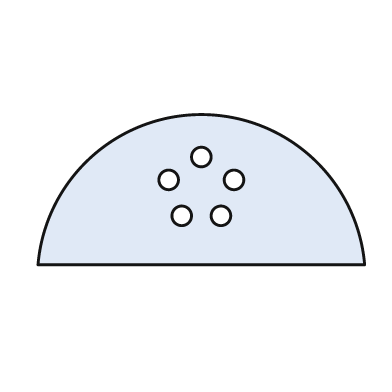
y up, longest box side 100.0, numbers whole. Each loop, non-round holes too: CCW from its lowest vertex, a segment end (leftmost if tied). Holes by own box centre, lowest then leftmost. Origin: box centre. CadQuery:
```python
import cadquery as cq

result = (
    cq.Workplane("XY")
    .moveTo(-50.0, -23.0)
    .lineTo(50.0, -23.0)
    .threePointArc((0.0, 23.0), (-50.0, -23.0))
    .close()
    .moveTo(-6.0, -8.0)
    .circle(3.0)
    .moveTo(6.0, -8.0)
    .circle(3.0)
    .moveTo(-10.0, 3.0)
    .circle(3.0)
    .moveTo(10.0, 3.0)
    .circle(3.0)
    .moveTo(0.0, 10.0)
    .circle(3.0)
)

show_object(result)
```